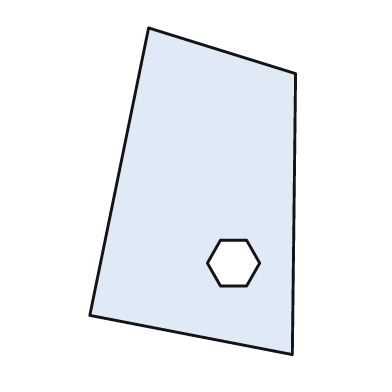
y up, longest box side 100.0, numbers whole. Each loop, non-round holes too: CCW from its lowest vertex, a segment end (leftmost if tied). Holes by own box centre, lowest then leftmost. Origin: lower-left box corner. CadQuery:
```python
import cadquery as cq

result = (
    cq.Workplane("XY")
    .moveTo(62.0, 0.0)
    .lineTo(63.0, 86.0)
    .lineTo(18.0, 100.0)
    .lineTo(0.0, 12.0)
    .close()
    .moveTo(40.0, 21.0)
    .lineTo(48.0, 21.0)
    .lineTo(52.0, 28.0)
    .lineTo(48.0, 35.0)
    .lineTo(40.0, 35.0)
    .lineTo(36.0, 28.0)
    .close()
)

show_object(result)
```